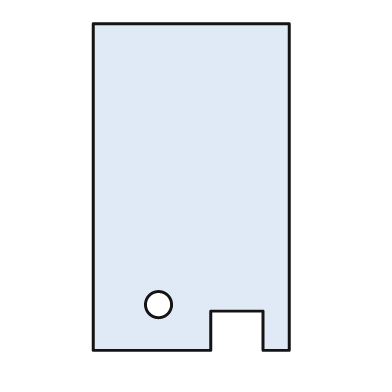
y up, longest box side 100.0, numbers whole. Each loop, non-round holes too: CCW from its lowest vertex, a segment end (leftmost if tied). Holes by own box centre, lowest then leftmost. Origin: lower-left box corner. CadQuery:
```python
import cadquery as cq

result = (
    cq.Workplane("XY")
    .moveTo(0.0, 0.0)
    .lineTo(36.0, 0.0)
    .lineTo(36.0, 12.0)
    .lineTo(52.0, 12.0)
    .lineTo(52.0, 0.0)
    .lineTo(60.0, 0.0)
    .lineTo(60.0, 100.0)
    .lineTo(0.0, 100.0)
    .close()
    .moveTo(20.0, 14.0)
    .circle(4.0)
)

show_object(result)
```